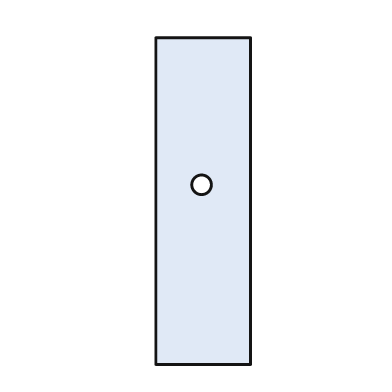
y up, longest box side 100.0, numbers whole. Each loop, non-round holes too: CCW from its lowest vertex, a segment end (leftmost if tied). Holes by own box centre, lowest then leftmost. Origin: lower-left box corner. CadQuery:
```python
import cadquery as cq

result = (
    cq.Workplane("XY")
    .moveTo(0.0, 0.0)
    .lineTo(29.0, 0.0)
    .lineTo(29.0, 100.0)
    .lineTo(0.0, 100.0)
    .close()
    .moveTo(14.0, 55.0)
    .circle(3.0)
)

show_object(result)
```